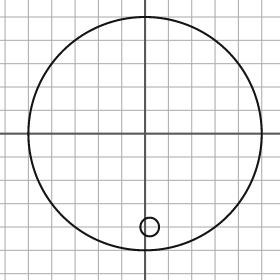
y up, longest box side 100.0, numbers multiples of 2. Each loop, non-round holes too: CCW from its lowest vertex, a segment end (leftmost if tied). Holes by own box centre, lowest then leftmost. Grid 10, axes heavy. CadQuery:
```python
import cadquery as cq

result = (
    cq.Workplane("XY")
    .moveTo(0.0, 0.0)
    .circle(50.0)
    .moveTo(2.0, -40.0)
    .circle(4.0)
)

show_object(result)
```